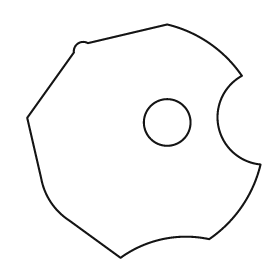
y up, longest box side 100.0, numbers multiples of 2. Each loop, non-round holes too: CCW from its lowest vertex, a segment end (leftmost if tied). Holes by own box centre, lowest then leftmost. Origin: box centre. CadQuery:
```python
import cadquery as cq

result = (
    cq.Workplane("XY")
    .moveTo(-10.0, -50.0)
    .threePointArc((8.0, -42.0), (28.0, -42.0))
    .threePointArc((42.0, -28.0), (50.0, -10.0))
    .threePointArc((32.0, 6.0), (42.0, 28.0))
    .threePointArc((28.0, 42.0), (10.0, 50.0))
    .lineTo(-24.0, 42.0)
    .threePointArc((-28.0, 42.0), (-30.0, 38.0))
    .lineTo(-50.0, 10.0)
    .lineTo(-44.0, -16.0)
    .threePointArc((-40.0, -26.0), (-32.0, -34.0))
    .close()
    .moveTo(10.0, 8.0)
    .circle(10.0)
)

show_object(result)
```